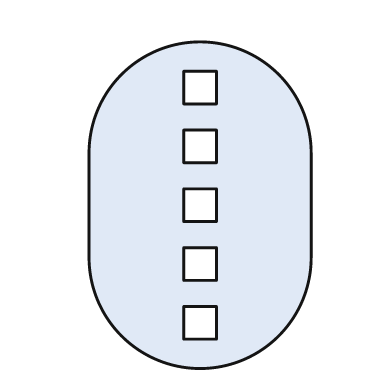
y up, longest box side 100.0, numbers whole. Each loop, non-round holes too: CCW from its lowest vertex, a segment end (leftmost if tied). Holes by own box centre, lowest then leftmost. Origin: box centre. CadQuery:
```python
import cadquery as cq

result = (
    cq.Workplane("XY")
    .moveTo(-34.0, -16.0)
    .threePointArc((0.0, -50.0), (34.0, -16.0))
    .lineTo(34.0, 16.0)
    .threePointArc((0.0, 50.0), (-34.0, 16.0))
    .close()
    .moveTo(-5.0, -41.0)
    .lineTo(5.0, -41.0)
    .lineTo(5.0, -31.0)
    .lineTo(-5.0, -31.0)
    .close()
    .moveTo(-5.0, -23.0)
    .lineTo(5.0, -23.0)
    .lineTo(5.0, -13.0)
    .lineTo(-5.0, -13.0)
    .close()
    .moveTo(-5.0, -5.0)
    .lineTo(5.0, -5.0)
    .lineTo(5.0, 5.0)
    .lineTo(-5.0, 5.0)
    .close()
    .moveTo(-5.0, 13.0)
    .lineTo(5.0, 13.0)
    .lineTo(5.0, 23.0)
    .lineTo(-5.0, 23.0)
    .close()
    .moveTo(-5.0, 31.0)
    .lineTo(5.0, 31.0)
    .lineTo(5.0, 41.0)
    .lineTo(-5.0, 41.0)
    .close()
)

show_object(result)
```